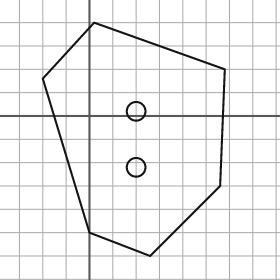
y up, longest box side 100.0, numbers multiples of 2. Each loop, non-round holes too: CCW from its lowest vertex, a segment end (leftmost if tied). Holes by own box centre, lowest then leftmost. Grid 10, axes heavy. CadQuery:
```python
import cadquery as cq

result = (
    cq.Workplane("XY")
    .moveTo(26.0, -60.0)
    .lineTo(56.0, -30.0)
    .lineTo(58.0, 20.0)
    .lineTo(2.0, 40.0)
    .lineTo(-20.0, 16.0)
    .lineTo(0.0, -50.0)
    .close()
    .moveTo(20.0, -22.0)
    .circle(4.0)
    .moveTo(20.0, 2.0)
    .circle(4.0)
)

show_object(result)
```